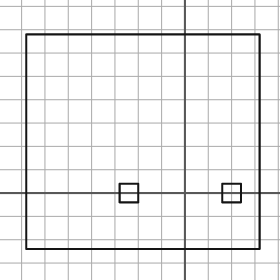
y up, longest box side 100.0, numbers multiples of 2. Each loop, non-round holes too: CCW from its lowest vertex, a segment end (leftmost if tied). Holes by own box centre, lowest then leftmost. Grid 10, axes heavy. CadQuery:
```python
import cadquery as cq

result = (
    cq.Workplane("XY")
    .moveTo(-68.0, -24.0)
    .lineTo(32.0, -24.0)
    .lineTo(32.0, 68.0)
    .lineTo(-68.0, 68.0)
    .close()
    .moveTo(-28.0, -4.0)
    .lineTo(-20.0, -4.0)
    .lineTo(-20.0, 4.0)
    .lineTo(-28.0, 4.0)
    .close()
    .moveTo(16.0, -4.0)
    .lineTo(24.0, -4.0)
    .lineTo(24.0, 4.0)
    .lineTo(16.0, 4.0)
    .close()
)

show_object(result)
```